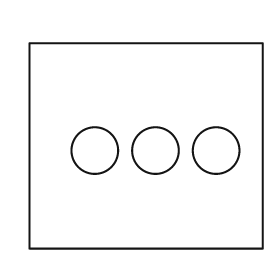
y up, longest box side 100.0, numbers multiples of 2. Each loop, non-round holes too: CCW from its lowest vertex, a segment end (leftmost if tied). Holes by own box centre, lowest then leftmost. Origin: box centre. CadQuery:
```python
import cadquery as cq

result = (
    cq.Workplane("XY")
    .moveTo(-50.0, -44.0)
    .lineTo(50.0, -44.0)
    .lineTo(50.0, 44.0)
    .lineTo(-50.0, 44.0)
    .close()
    .moveTo(-22.0, -2.0)
    .circle(10.0)
    .moveTo(4.0, -2.0)
    .circle(10.0)
    .moveTo(30.0, -2.0)
    .circle(10.0)
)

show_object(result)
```